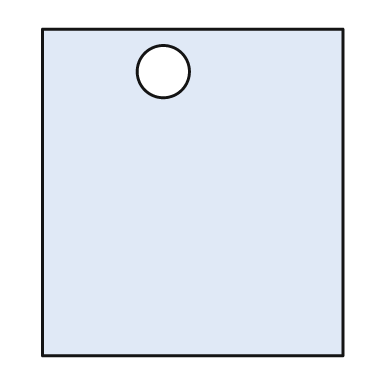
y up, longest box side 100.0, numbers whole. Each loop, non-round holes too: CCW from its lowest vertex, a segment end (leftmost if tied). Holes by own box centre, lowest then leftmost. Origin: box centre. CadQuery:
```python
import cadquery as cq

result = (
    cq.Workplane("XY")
    .moveTo(-46.0, -50.0)
    .lineTo(46.0, -50.0)
    .lineTo(46.0, 50.0)
    .lineTo(-46.0, 50.0)
    .close()
    .moveTo(-9.0, 37.0)
    .circle(8.0)
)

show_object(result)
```